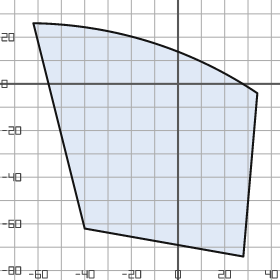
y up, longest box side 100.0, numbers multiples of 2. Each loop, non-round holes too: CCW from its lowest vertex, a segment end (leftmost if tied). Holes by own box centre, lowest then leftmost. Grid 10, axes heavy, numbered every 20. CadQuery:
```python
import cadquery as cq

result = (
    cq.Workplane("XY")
    .moveTo(28.0, -74.0)
    .lineTo(34.0, -4.0)
    .threePointArc((-12.0, 18.0), (-62.0, 26.0))
    .lineTo(-40.0, -62.0)
    .close()
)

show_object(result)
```